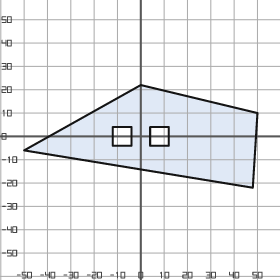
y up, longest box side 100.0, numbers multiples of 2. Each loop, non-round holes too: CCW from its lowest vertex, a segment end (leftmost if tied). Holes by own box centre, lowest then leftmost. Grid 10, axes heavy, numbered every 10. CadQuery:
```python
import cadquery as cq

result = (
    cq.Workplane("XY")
    .moveTo(48.0, -22.0)
    .lineTo(50.0, 10.0)
    .lineTo(0.0, 22.0)
    .lineTo(-50.0, -6.0)
    .close()
    .moveTo(-12.0, -4.0)
    .lineTo(-4.0, -4.0)
    .lineTo(-4.0, 4.0)
    .lineTo(-12.0, 4.0)
    .close()
    .moveTo(4.0, -4.0)
    .lineTo(12.0, -4.0)
    .lineTo(12.0, 4.0)
    .lineTo(4.0, 4.0)
    .close()
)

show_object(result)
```